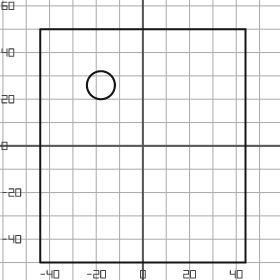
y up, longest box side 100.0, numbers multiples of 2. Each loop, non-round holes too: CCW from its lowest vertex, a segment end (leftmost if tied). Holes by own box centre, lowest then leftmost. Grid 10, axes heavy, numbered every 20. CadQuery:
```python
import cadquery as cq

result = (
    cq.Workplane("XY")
    .moveTo(-44.0, -50.0)
    .lineTo(44.0, -50.0)
    .lineTo(44.0, 50.0)
    .lineTo(-44.0, 50.0)
    .close()
    .moveTo(-18.0, 26.0)
    .circle(6.0)
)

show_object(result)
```